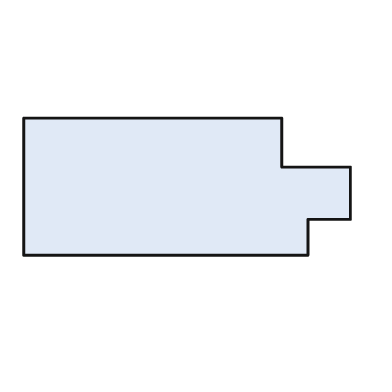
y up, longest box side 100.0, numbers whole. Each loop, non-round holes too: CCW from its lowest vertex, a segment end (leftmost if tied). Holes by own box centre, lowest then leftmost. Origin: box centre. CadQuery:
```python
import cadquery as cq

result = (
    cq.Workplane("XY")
    .moveTo(-50.0, -21.0)
    .lineTo(37.0, -21.0)
    .lineTo(37.0, -10.0)
    .lineTo(50.0, -10.0)
    .lineTo(50.0, 6.0)
    .lineTo(29.0, 6.0)
    .lineTo(29.0, 21.0)
    .lineTo(-50.0, 21.0)
    .close()
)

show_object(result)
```